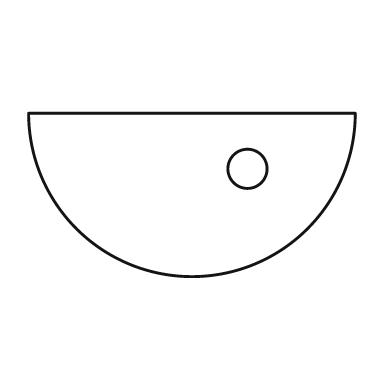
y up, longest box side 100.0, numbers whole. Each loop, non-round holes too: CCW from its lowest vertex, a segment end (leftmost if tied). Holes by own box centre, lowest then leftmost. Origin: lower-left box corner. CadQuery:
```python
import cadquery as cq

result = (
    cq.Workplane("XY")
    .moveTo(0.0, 50.0)
    .threePointArc((50.0, 0.0), (100.0, 50.0))
    .close()
    .moveTo(67.0, 33.0)
    .circle(6.0)
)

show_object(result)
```